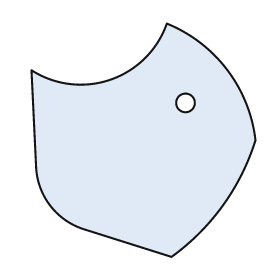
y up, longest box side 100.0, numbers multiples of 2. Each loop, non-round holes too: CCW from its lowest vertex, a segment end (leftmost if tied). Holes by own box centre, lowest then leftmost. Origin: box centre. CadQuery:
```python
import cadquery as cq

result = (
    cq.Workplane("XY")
    .moveTo(12.0, -50.0)
    .threePointArc((34.0, -28.0), (48.0, 0.0))
    .threePointArc((36.0, 30.0), (10.0, 50.0))
    .threePointArc((-14.0, 26.0), (-48.0, 30.0))
    .lineTo(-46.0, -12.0)
    .threePointArc((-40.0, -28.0), (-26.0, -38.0))
    .close()
    .moveTo(18.0, 16.0)
    .circle(4.0)
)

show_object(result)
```